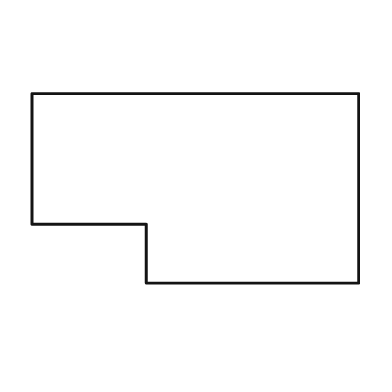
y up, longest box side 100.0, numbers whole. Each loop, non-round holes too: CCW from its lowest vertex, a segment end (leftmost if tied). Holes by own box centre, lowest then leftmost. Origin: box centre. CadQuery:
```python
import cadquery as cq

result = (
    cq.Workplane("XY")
    .moveTo(-15.0, -29.0)
    .lineTo(50.0, -29.0)
    .lineTo(50.0, 29.0)
    .lineTo(-50.0, 29.0)
    .lineTo(-50.0, -11.0)
    .lineTo(-15.0, -11.0)
    .close()
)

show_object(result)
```